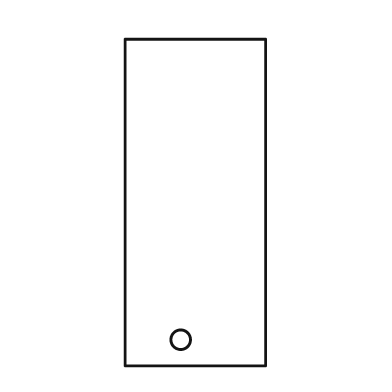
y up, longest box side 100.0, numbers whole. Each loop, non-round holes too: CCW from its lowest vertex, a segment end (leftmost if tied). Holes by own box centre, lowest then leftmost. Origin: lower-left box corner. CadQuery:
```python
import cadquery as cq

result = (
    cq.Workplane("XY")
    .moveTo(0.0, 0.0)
    .lineTo(43.0, 0.0)
    .lineTo(43.0, 100.0)
    .lineTo(0.0, 100.0)
    .close()
    .moveTo(17.0, 8.0)
    .circle(3.0)
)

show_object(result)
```